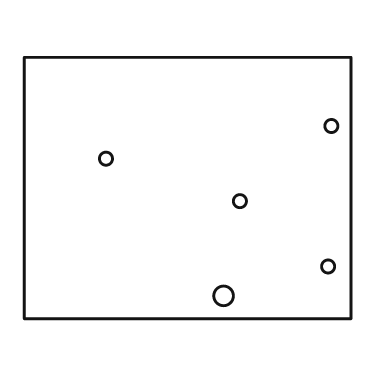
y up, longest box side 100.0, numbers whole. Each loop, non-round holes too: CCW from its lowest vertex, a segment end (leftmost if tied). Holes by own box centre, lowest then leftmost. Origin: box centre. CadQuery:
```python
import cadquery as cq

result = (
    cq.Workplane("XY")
    .moveTo(-50.0, -40.0)
    .lineTo(50.0, -40.0)
    .lineTo(50.0, 40.0)
    .lineTo(-50.0, 40.0)
    .close()
    .moveTo(11.0, -33.0)
    .circle(3.0)
    .moveTo(43.0, -24.0)
    .circle(2.0)
    .moveTo(16.0, -4.0)
    .circle(2.0)
    .moveTo(-25.0, 9.0)
    .circle(2.0)
    .moveTo(44.0, 19.0)
    .circle(2.0)
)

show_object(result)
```